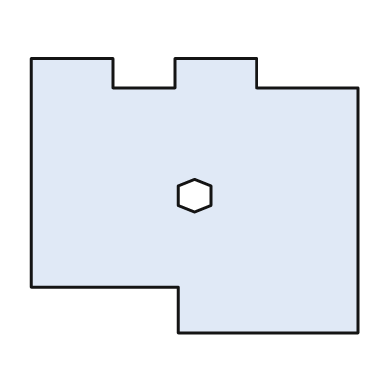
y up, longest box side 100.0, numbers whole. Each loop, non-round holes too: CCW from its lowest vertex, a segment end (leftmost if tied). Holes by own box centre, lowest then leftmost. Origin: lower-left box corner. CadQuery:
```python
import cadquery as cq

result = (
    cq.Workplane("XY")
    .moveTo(45.0, 0.0)
    .lineTo(100.0, 0.0)
    .lineTo(100.0, 75.0)
    .lineTo(69.0, 75.0)
    .lineTo(69.0, 84.0)
    .lineTo(44.0, 84.0)
    .lineTo(44.0, 75.0)
    .lineTo(25.0, 75.0)
    .lineTo(25.0, 84.0)
    .lineTo(0.0, 84.0)
    .lineTo(0.0, 14.0)
    .lineTo(45.0, 14.0)
    .close()
    .moveTo(50.0, 37.0)
    .lineTo(55.0, 39.0)
    .lineTo(55.0, 45.0)
    .lineTo(50.0, 47.0)
    .lineTo(45.0, 45.0)
    .lineTo(45.0, 39.0)
    .close()
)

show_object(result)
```